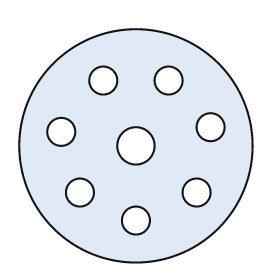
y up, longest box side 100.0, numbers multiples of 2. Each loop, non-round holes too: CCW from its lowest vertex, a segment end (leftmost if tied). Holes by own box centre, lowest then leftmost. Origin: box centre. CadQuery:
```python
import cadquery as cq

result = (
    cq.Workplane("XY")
    .moveTo(0.0, 0.0)
    .circle(50.0)
    .moveTo(0.0, -32.0)
    .circle(6.0)
    .moveTo(-24.0, -20.0)
    .circle(6.0)
    .moveTo(26.0, -20.0)
    .circle(6.0)
    .moveTo(0.0, 0.0)
    .circle(8.0)
    .moveTo(-32.0, 6.0)
    .circle(6.0)
    .moveTo(32.0, 8.0)
    .circle(6.0)
    .moveTo(-14.0, 28.0)
    .circle(6.0)
    .moveTo(14.0, 28.0)
    .circle(6.0)
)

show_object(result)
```